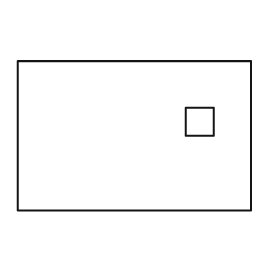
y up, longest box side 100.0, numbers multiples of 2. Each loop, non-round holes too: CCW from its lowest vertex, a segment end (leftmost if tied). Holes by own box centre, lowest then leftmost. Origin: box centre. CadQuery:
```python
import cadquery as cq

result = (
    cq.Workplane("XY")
    .moveTo(-50.0, -32.0)
    .lineTo(50.0, -32.0)
    .lineTo(50.0, 32.0)
    .lineTo(-50.0, 32.0)
    .close()
    .moveTo(22.0, 0.0)
    .lineTo(34.0, 0.0)
    .lineTo(34.0, 12.0)
    .lineTo(22.0, 12.0)
    .close()
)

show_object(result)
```